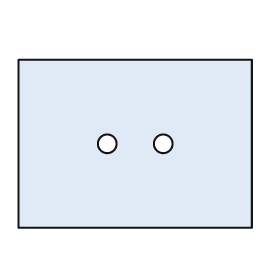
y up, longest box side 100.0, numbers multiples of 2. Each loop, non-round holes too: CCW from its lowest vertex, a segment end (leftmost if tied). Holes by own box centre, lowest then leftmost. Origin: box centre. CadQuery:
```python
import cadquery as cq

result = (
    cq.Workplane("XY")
    .moveTo(-50.0, -36.0)
    .lineTo(50.0, -36.0)
    .lineTo(50.0, 36.0)
    .lineTo(-50.0, 36.0)
    .close()
    .moveTo(-12.0, 0.0)
    .circle(4.0)
    .moveTo(12.0, 0.0)
    .circle(4.0)
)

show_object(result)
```